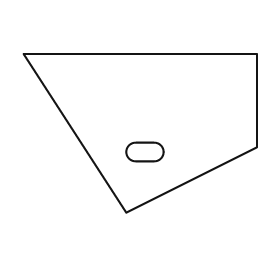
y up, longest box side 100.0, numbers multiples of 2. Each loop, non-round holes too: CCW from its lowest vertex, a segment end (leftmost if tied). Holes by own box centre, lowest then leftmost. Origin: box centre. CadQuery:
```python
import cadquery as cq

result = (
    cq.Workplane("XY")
    .moveTo(-6.0, -34.0)
    .lineTo(50.0, -6.0)
    .lineTo(50.0, 34.0)
    .lineTo(-50.0, 34.0)
    .close()
    .moveTo(-2.0, -12.0)
    .lineTo(6.0, -12.0)
    .threePointArc((10.0, -8.0), (6.0, -4.0))
    .lineTo(-2.0, -4.0)
    .threePointArc((-6.0, -8.0), (-2.0, -12.0))
    .close()
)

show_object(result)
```